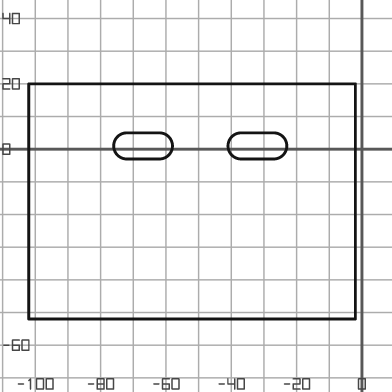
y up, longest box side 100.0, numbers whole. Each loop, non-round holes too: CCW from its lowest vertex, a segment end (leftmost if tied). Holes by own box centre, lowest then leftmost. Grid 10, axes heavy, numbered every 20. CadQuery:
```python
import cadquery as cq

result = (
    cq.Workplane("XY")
    .moveTo(-102.0, -52.0)
    .lineTo(-2.0, -52.0)
    .lineTo(-2.0, 20.0)
    .lineTo(-102.0, 20.0)
    .close()
    .moveTo(-72.0, -3.0)
    .lineTo(-62.0, -3.0)
    .threePointArc((-58.0, 1.0), (-62.0, 5.0))
    .lineTo(-72.0, 5.0)
    .threePointArc((-76.0, 1.0), (-72.0, -3.0))
    .close()
    .moveTo(-37.0, -3.0)
    .lineTo(-27.0, -3.0)
    .threePointArc((-23.0, 1.0), (-27.0, 5.0))
    .lineTo(-37.0, 5.0)
    .threePointArc((-41.0, 1.0), (-37.0, -3.0))
    .close()
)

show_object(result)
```